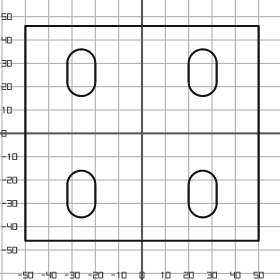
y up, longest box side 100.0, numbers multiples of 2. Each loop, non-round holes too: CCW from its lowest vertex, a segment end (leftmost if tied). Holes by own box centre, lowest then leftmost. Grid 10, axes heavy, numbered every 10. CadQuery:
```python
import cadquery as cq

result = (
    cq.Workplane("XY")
    .moveTo(-50.0, -46.0)
    .lineTo(50.0, -46.0)
    .lineTo(50.0, 46.0)
    .lineTo(-50.0, 46.0)
    .close()
    .moveTo(-32.0, -30.0)
    .threePointArc((-26.0, -36.0), (-20.0, -30.0))
    .lineTo(-20.0, -22.0)
    .threePointArc((-26.0, -16.0), (-32.0, -22.0))
    .close()
    .moveTo(20.0, -30.0)
    .threePointArc((26.0, -36.0), (32.0, -30.0))
    .lineTo(32.0, -22.0)
    .threePointArc((26.0, -16.0), (20.0, -22.0))
    .close()
    .moveTo(-32.0, 22.0)
    .threePointArc((-26.0, 16.0), (-20.0, 22.0))
    .lineTo(-20.0, 30.0)
    .threePointArc((-26.0, 36.0), (-32.0, 30.0))
    .close()
    .moveTo(20.0, 22.0)
    .threePointArc((26.0, 16.0), (32.0, 22.0))
    .lineTo(32.0, 30.0)
    .threePointArc((26.0, 36.0), (20.0, 30.0))
    .close()
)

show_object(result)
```